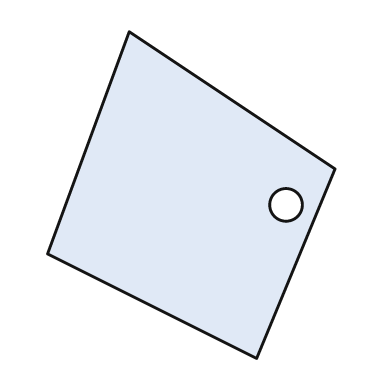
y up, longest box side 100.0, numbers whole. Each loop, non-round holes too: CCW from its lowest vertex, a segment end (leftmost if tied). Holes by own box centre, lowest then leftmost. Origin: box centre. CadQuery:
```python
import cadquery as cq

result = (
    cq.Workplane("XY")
    .moveTo(20.0, -50.0)
    .lineTo(44.0, 8.0)
    .lineTo(-19.0, 50.0)
    .lineTo(-44.0, -18.0)
    .close()
    .moveTo(29.0, -3.0)
    .circle(5.0)
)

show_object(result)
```